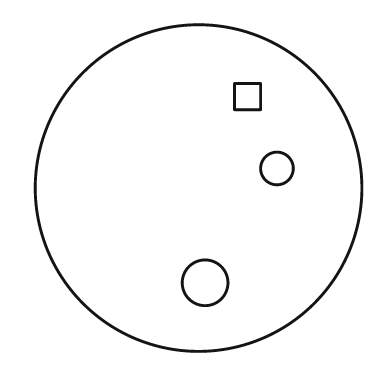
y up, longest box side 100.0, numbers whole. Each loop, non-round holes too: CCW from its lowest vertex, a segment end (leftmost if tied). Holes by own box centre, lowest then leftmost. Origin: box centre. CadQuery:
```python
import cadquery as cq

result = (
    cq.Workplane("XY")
    .moveTo(0.0, 0.0)
    .circle(50.0)
    .moveTo(2.0, -29.0)
    .circle(7.0)
    .moveTo(24.0, 6.0)
    .circle(5.0)
    .moveTo(11.0, 24.0)
    .lineTo(19.0, 24.0)
    .lineTo(19.0, 32.0)
    .lineTo(11.0, 32.0)
    .close()
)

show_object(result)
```